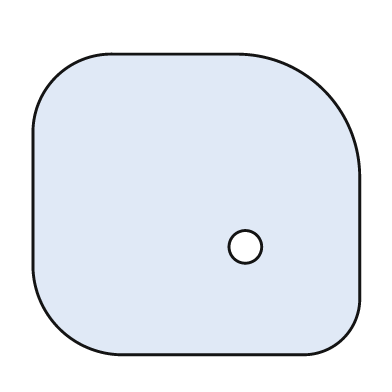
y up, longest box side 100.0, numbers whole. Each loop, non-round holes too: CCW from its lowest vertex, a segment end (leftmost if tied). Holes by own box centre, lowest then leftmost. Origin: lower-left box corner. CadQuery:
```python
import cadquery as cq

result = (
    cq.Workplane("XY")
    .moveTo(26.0, 0.0)
    .lineTo(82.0, 0.0)
    .threePointArc((95.0, 5.0), (100.0, 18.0))
    .lineTo(100.0, 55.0)
    .threePointArc((89.0, 81.0), (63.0, 92.0))
    .lineTo(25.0, 92.0)
    .threePointArc((7.0, 85.0), (0.0, 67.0))
    .lineTo(0.0, 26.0)
    .threePointArc((8.0, 8.0), (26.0, 0.0))
    .close()
    .moveTo(65.0, 33.0)
    .circle(5.0)
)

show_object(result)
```